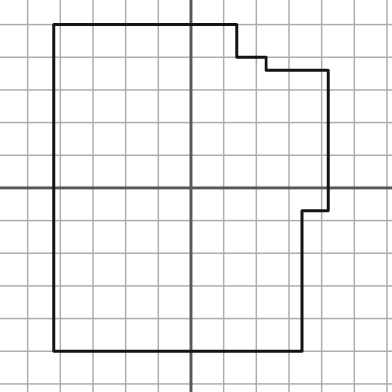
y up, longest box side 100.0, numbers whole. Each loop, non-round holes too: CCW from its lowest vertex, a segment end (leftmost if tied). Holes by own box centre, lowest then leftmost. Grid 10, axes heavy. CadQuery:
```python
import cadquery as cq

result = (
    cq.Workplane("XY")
    .moveTo(-42.0, -50.0)
    .lineTo(34.0, -50.0)
    .lineTo(34.0, -7.0)
    .lineTo(42.0, -7.0)
    .lineTo(42.0, 36.0)
    .lineTo(23.0, 36.0)
    .lineTo(23.0, 40.0)
    .lineTo(14.0, 40.0)
    .lineTo(14.0, 50.0)
    .lineTo(-42.0, 50.0)
    .close()
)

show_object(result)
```